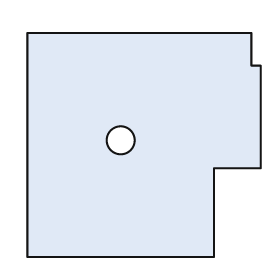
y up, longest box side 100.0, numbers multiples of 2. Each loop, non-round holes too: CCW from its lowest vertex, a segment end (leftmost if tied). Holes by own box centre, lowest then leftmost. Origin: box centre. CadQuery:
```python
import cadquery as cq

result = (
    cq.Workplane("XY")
    .moveTo(-50.0, -48.0)
    .lineTo(30.0, -48.0)
    .lineTo(30.0, -10.0)
    .lineTo(50.0, -10.0)
    .lineTo(50.0, 34.0)
    .lineTo(46.0, 34.0)
    .lineTo(46.0, 48.0)
    .lineTo(-50.0, 48.0)
    .close()
    .moveTo(-10.0, 2.0)
    .circle(6.0)
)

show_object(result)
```